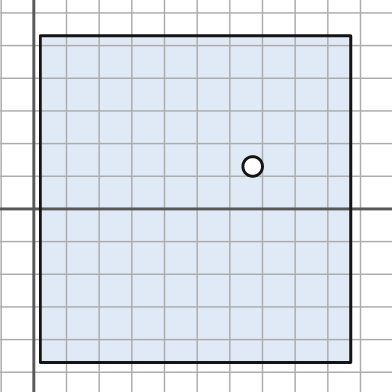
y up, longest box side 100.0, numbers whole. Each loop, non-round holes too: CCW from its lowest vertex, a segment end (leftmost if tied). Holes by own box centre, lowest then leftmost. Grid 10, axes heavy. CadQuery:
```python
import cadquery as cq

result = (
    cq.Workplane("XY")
    .moveTo(2.0, -47.0)
    .lineTo(97.0, -47.0)
    .lineTo(97.0, 53.0)
    .lineTo(2.0, 53.0)
    .close()
    .moveTo(67.0, 13.0)
    .circle(3.0)
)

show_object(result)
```